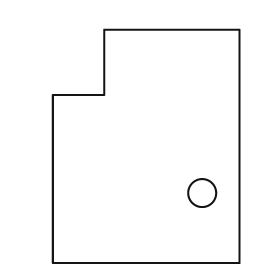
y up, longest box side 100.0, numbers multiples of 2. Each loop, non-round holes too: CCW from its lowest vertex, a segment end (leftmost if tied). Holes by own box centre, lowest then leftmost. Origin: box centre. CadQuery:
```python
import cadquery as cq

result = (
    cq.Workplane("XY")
    .moveTo(-40.0, -50.0)
    .lineTo(40.0, -50.0)
    .lineTo(40.0, 50.0)
    .lineTo(-18.0, 50.0)
    .lineTo(-18.0, 22.0)
    .lineTo(-40.0, 22.0)
    .close()
    .moveTo(24.0, -20.0)
    .circle(6.0)
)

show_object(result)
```